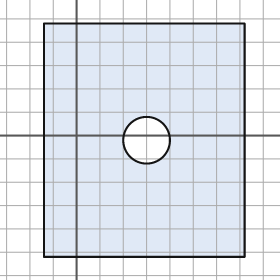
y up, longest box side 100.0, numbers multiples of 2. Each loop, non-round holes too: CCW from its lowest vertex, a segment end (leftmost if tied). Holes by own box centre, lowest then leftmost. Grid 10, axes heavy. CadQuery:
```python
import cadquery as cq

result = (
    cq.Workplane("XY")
    .moveTo(-14.0, -52.0)
    .lineTo(72.0, -52.0)
    .lineTo(72.0, 48.0)
    .lineTo(-14.0, 48.0)
    .close()
    .moveTo(30.0, -2.0)
    .circle(10.0)
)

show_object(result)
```